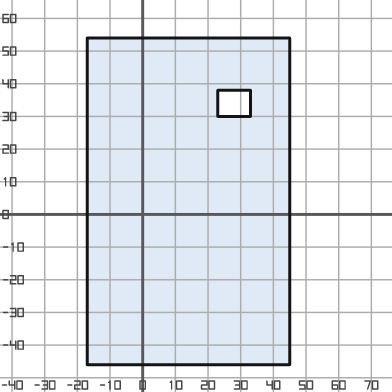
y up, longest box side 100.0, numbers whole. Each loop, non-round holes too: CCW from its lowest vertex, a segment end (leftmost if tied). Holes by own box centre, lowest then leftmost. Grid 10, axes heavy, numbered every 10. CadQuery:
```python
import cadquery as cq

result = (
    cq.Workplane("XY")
    .moveTo(-17.0, -46.0)
    .lineTo(45.0, -46.0)
    .lineTo(45.0, 54.0)
    .lineTo(-17.0, 54.0)
    .close()
    .moveTo(23.0, 30.0)
    .lineTo(33.0, 30.0)
    .lineTo(33.0, 38.0)
    .lineTo(23.0, 38.0)
    .close()
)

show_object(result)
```